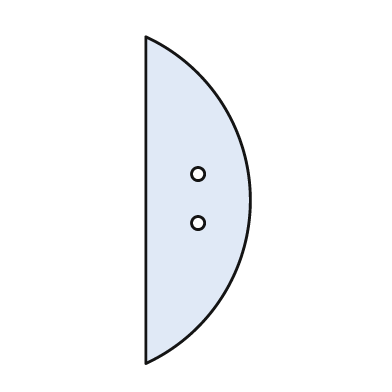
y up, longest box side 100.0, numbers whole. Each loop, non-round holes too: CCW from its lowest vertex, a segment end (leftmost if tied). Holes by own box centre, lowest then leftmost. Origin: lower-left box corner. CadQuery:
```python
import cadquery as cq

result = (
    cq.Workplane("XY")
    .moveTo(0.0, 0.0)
    .threePointArc((32.0, 50.0), (0.0, 100.0))
    .close()
    .moveTo(16.0, 43.0)
    .circle(2.0)
    .moveTo(16.0, 58.0)
    .circle(2.0)
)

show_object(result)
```